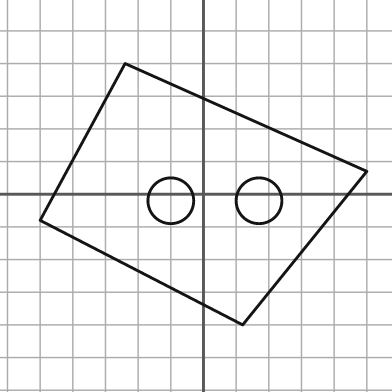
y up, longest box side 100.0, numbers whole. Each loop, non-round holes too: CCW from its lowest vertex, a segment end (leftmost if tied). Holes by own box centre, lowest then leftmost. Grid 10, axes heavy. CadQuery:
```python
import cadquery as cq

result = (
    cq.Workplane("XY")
    .moveTo(12.0, -40.0)
    .lineTo(50.0, 7.0)
    .lineTo(-24.0, 40.0)
    .lineTo(-50.0, -8.0)
    .close()
    .moveTo(-10.0, -2.0)
    .circle(7.0)
    .moveTo(17.0, -2.0)
    .circle(7.0)
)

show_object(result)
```